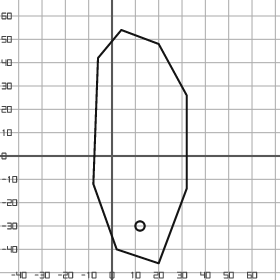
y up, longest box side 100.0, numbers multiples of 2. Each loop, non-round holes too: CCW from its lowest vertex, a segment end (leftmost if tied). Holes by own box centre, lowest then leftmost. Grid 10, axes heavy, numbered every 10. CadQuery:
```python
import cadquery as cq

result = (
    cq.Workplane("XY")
    .moveTo(20.0, -46.0)
    .lineTo(32.0, -14.0)
    .lineTo(32.0, 26.0)
    .lineTo(20.0, 48.0)
    .lineTo(4.0, 54.0)
    .lineTo(-6.0, 42.0)
    .lineTo(-8.0, -12.0)
    .lineTo(2.0, -40.0)
    .close()
    .moveTo(12.0, -30.0)
    .circle(2.0)
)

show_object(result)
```